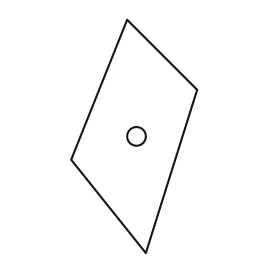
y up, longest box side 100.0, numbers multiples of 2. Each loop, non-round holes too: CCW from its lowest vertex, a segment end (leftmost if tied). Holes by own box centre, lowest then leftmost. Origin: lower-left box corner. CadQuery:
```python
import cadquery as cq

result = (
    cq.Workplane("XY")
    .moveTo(32.0, 0.0)
    .lineTo(54.0, 70.0)
    .lineTo(24.0, 100.0)
    .lineTo(0.0, 40.0)
    .close()
    .moveTo(28.0, 50.0)
    .circle(4.0)
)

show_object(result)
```